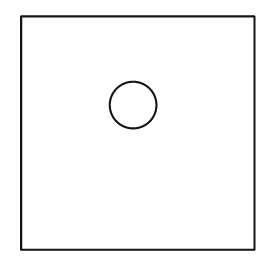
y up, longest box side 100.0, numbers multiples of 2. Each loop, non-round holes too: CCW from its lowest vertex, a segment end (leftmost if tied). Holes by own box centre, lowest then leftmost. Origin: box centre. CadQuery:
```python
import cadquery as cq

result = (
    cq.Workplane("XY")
    .moveTo(-50.0, -50.0)
    .lineTo(50.0, -50.0)
    .lineTo(50.0, 50.0)
    .lineTo(-50.0, 50.0)
    .close()
    .moveTo(-2.0, 12.0)
    .circle(10.0)
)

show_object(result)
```